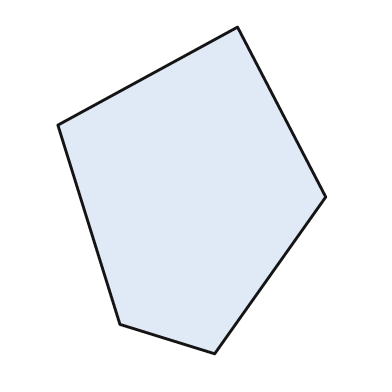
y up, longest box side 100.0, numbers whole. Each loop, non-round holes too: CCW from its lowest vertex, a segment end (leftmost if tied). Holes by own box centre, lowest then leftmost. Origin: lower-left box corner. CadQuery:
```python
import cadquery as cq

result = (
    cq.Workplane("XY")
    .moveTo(48.0, 0.0)
    .lineTo(82.0, 48.0)
    .lineTo(55.0, 100.0)
    .lineTo(0.0, 70.0)
    .lineTo(19.0, 9.0)
    .close()
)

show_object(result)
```